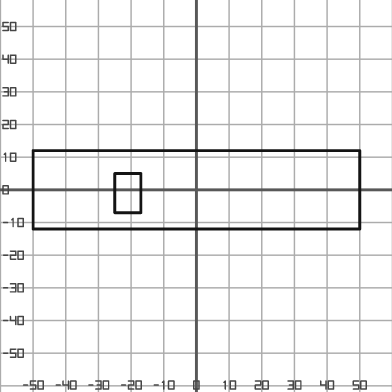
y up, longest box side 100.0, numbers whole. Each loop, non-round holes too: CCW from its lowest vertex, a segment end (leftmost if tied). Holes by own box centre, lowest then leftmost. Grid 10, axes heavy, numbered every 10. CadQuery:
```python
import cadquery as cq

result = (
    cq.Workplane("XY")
    .moveTo(-50.0, -12.0)
    .lineTo(50.0, -12.0)
    .lineTo(50.0, 12.0)
    .lineTo(-50.0, 12.0)
    .close()
    .moveTo(-25.0, -7.0)
    .lineTo(-17.0, -7.0)
    .lineTo(-17.0, 5.0)
    .lineTo(-25.0, 5.0)
    .close()
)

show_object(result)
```